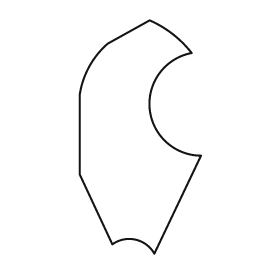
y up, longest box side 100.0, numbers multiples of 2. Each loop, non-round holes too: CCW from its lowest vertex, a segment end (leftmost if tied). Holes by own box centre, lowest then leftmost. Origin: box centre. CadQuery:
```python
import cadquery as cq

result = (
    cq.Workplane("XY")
    .moveTo(6.0, -50.0)
    .lineTo(26.0, -8.0)
    .threePointArc((4.0, 12.0), (22.0, 36.0))
    .threePointArc((14.0, 44.0), (4.0, 50.0))
    .lineTo(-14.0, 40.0)
    .threePointArc((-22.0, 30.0), (-26.0, 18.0))
    .lineTo(-26.0, -16.0)
    .lineTo(-12.0, -46.0)
    .threePointArc((-2.0, -44.0), (6.0, -50.0))
    .close()
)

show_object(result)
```